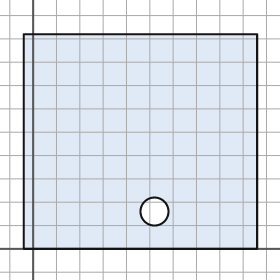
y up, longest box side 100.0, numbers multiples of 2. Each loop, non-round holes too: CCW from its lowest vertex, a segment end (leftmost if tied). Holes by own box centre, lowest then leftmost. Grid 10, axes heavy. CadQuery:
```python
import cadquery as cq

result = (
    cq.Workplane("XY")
    .moveTo(-4.0, 0.0)
    .lineTo(96.0, 0.0)
    .lineTo(96.0, 92.0)
    .lineTo(-4.0, 92.0)
    .close()
    .moveTo(52.0, 16.0)
    .circle(6.0)
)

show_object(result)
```